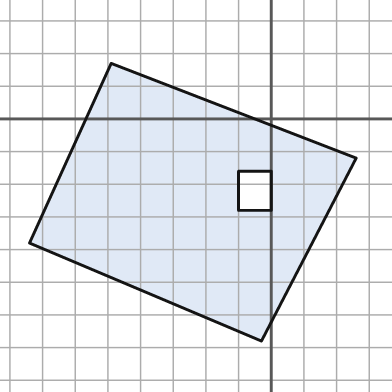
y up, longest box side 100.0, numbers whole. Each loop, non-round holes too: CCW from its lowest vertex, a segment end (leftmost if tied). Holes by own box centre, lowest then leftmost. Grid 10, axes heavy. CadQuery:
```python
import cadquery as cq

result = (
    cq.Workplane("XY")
    .moveTo(-3.0, -68.0)
    .lineTo(26.0, -12.0)
    .lineTo(-49.0, 17.0)
    .lineTo(-74.0, -38.0)
    .close()
    .moveTo(-10.0, -28.0)
    .lineTo(0.0, -28.0)
    .lineTo(0.0, -16.0)
    .lineTo(-10.0, -16.0)
    .close()
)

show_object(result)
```